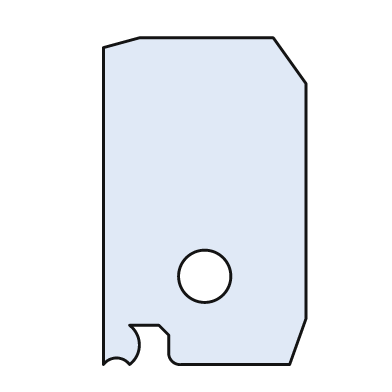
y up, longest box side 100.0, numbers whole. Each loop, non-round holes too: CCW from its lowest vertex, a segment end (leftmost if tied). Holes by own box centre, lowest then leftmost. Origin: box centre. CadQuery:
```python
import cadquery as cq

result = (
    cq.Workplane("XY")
    .moveTo(-31.0, -50.0)
    .threePointArc((-27.0, -48.0), (-23.0, -50.0))
    .threePointArc((-20.0, -44.0), (-23.0, -38.0))
    .lineTo(-14.0, -38.0)
    .lineTo(-11.0, -41.0)
    .lineTo(-11.0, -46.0)
    .threePointArc((-10.0, -49.0), (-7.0, -50.0))
    .lineTo(26.0, -50.0)
    .lineTo(31.0, -36.0)
    .lineTo(31.0, 36.0)
    .lineTo(21.0, 50.0)
    .lineTo(-20.0, 50.0)
    .lineTo(-31.0, 47.0)
    .close()
    .moveTo(0.0, -23.0)
    .circle(8.0)
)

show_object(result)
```